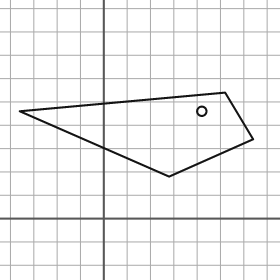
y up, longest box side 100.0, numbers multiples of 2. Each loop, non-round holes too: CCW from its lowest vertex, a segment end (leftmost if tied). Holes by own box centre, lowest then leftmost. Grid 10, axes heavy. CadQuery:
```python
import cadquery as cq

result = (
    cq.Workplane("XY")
    .moveTo(28.0, 18.0)
    .lineTo(64.0, 34.0)
    .lineTo(52.0, 54.0)
    .lineTo(-36.0, 46.0)
    .close()
    .moveTo(42.0, 46.0)
    .circle(2.0)
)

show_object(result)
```